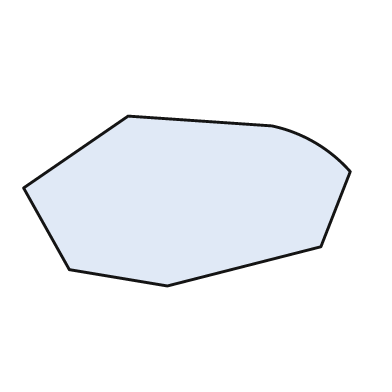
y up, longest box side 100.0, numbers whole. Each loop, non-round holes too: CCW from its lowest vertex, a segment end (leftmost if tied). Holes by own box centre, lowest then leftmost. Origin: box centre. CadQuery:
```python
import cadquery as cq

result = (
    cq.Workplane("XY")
    .moveTo(-6.0, -26.0)
    .lineTo(41.0, -14.0)
    .lineTo(50.0, 9.0)
    .threePointArc((39.0, 18.0), (26.0, 23.0))
    .lineTo(-18.0, 26.0)
    .lineTo(-50.0, 4.0)
    .lineTo(-36.0, -21.0)
    .close()
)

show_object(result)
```